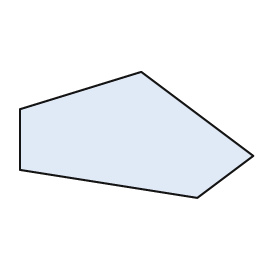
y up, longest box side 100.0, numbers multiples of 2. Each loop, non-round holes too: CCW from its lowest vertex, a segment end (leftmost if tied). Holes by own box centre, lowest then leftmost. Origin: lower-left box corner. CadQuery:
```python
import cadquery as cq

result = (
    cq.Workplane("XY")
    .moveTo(76.0, 0.0)
    .lineTo(100.0, 18.0)
    .lineTo(52.0, 54.0)
    .lineTo(0.0, 38.0)
    .lineTo(0.0, 12.0)
    .close()
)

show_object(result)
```